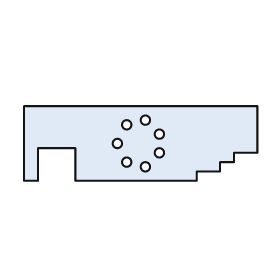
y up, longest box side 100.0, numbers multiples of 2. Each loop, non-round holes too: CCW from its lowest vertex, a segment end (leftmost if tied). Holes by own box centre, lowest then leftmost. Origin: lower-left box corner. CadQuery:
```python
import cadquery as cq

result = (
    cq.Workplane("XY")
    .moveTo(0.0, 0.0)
    .lineTo(6.0, 0.0)
    .lineTo(6.0, 14.0)
    .lineTo(22.0, 14.0)
    .lineTo(22.0, 0.0)
    .lineTo(74.0, 0.0)
    .lineTo(74.0, 4.0)
    .lineTo(84.0, 4.0)
    .lineTo(84.0, 8.0)
    .lineTo(90.0, 8.0)
    .lineTo(90.0, 12.0)
    .lineTo(100.0, 12.0)
    .lineTo(100.0, 32.0)
    .lineTo(0.0, 32.0)
    .close()
    .moveTo(52.0, 6.0)
    .circle(2.0)
    .moveTo(44.0, 8.0)
    .circle(2.0)
    .moveTo(58.0, 12.0)
    .circle(2.0)
    .moveTo(40.0, 16.0)
    .circle(2.0)
    .moveTo(58.0, 20.0)
    .circle(2.0)
    .moveTo(44.0, 24.0)
    .circle(2.0)
    .moveTo(52.0, 26.0)
    .circle(2.0)
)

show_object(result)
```